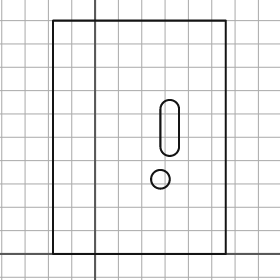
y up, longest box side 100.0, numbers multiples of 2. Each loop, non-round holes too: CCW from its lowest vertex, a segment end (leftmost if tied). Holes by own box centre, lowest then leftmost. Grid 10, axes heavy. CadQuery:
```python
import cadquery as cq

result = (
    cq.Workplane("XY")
    .moveTo(-18.0, 0.0)
    .lineTo(56.0, 0.0)
    .lineTo(56.0, 100.0)
    .lineTo(-18.0, 100.0)
    .close()
    .moveTo(28.0, 32.0)
    .circle(4.0)
    .moveTo(28.0, 46.0)
    .threePointArc((32.0, 42.0), (36.0, 46.0))
    .lineTo(36.0, 62.0)
    .threePointArc((32.0, 66.0), (28.0, 62.0))
    .close()
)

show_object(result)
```